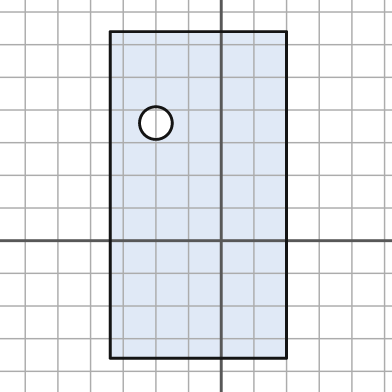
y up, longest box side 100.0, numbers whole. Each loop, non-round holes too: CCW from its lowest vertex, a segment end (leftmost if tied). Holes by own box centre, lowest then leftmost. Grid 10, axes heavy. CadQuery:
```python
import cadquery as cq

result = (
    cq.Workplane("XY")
    .moveTo(-34.0, -36.0)
    .lineTo(20.0, -36.0)
    .lineTo(20.0, 64.0)
    .lineTo(-34.0, 64.0)
    .close()
    .moveTo(-20.0, 36.0)
    .circle(5.0)
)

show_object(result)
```